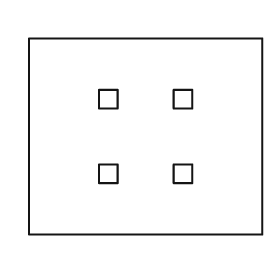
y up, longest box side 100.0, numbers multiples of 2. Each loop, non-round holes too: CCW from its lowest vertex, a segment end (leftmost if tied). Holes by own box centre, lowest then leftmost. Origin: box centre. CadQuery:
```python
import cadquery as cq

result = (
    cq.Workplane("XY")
    .moveTo(-50.0, -42.0)
    .lineTo(50.0, -42.0)
    .lineTo(50.0, 42.0)
    .lineTo(-50.0, 42.0)
    .close()
    .moveTo(-20.0, -20.0)
    .lineTo(-12.0, -20.0)
    .lineTo(-12.0, -12.0)
    .lineTo(-20.0, -12.0)
    .close()
    .moveTo(12.0, -20.0)
    .lineTo(20.0, -20.0)
    .lineTo(20.0, -12.0)
    .lineTo(12.0, -12.0)
    .close()
    .moveTo(-20.0, 12.0)
    .lineTo(-12.0, 12.0)
    .lineTo(-12.0, 20.0)
    .lineTo(-20.0, 20.0)
    .close()
    .moveTo(12.0, 12.0)
    .lineTo(20.0, 12.0)
    .lineTo(20.0, 20.0)
    .lineTo(12.0, 20.0)
    .close()
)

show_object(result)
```